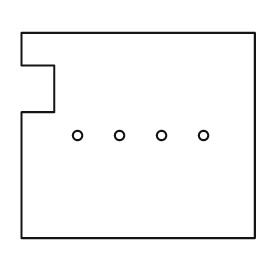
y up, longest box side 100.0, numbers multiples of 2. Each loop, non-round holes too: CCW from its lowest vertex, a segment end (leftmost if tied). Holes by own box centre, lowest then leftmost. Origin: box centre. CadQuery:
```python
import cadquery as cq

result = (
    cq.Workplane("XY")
    .moveTo(-50.0, -44.0)
    .lineTo(50.0, -44.0)
    .lineTo(50.0, 44.0)
    .lineTo(-50.0, 44.0)
    .lineTo(-50.0, 30.0)
    .lineTo(-36.0, 30.0)
    .lineTo(-36.0, 10.0)
    .lineTo(-50.0, 10.0)
    .close()
    .moveTo(-26.0, 0.0)
    .circle(2.0)
    .moveTo(-8.0, 0.0)
    .circle(2.0)
    .moveTo(10.0, 0.0)
    .circle(2.0)
    .moveTo(28.0, 0.0)
    .circle(2.0)
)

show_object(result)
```